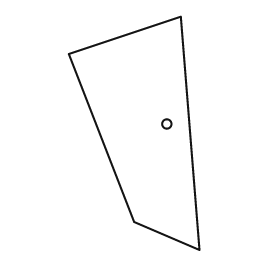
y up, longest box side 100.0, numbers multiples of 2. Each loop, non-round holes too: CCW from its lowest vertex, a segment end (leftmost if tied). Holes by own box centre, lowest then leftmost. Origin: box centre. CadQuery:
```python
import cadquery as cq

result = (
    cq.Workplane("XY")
    .moveTo(28.0, -50.0)
    .lineTo(20.0, 50.0)
    .lineTo(-28.0, 34.0)
    .lineTo(0.0, -38.0)
    .close()
    .moveTo(14.0, 4.0)
    .circle(2.0)
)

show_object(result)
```